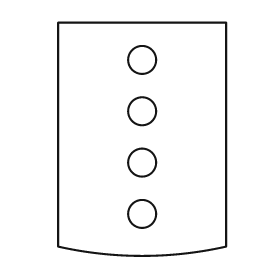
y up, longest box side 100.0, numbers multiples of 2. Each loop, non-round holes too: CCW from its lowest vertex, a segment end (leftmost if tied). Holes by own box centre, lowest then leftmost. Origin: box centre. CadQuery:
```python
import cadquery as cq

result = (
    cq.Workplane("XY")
    .moveTo(-36.0, -46.0)
    .threePointArc((0.0, -50.0), (36.0, -46.0))
    .lineTo(36.0, 50.0)
    .lineTo(-36.0, 50.0)
    .close()
    .moveTo(0.0, -32.0)
    .circle(6.0)
    .moveTo(0.0, -10.0)
    .circle(6.0)
    .moveTo(0.0, 12.0)
    .circle(6.0)
    .moveTo(0.0, 34.0)
    .circle(6.0)
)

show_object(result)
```